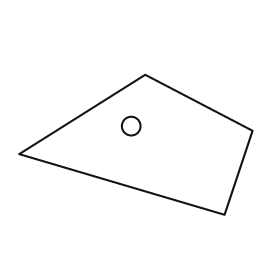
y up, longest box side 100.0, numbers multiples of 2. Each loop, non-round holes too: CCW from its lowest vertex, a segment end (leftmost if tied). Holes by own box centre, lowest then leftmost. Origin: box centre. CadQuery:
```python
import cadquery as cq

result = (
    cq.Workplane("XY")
    .moveTo(38.0, -30.0)
    .lineTo(50.0, 6.0)
    .lineTo(4.0, 30.0)
    .lineTo(-50.0, -4.0)
    .close()
    .moveTo(-2.0, 8.0)
    .circle(4.0)
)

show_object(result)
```